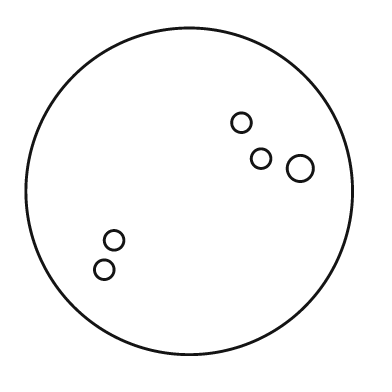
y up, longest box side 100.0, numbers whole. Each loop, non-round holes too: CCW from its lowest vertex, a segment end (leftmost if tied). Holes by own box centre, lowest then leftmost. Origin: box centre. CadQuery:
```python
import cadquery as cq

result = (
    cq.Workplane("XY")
    .moveTo(0.0, 0.0)
    .circle(50.0)
    .moveTo(-26.0, -24.0)
    .circle(3.0)
    .moveTo(-23.0, -15.0)
    .circle(3.0)
    .moveTo(34.0, 7.0)
    .circle(4.0)
    .moveTo(22.0, 10.0)
    .circle(3.0)
    .moveTo(16.0, 21.0)
    .circle(3.0)
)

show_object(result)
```